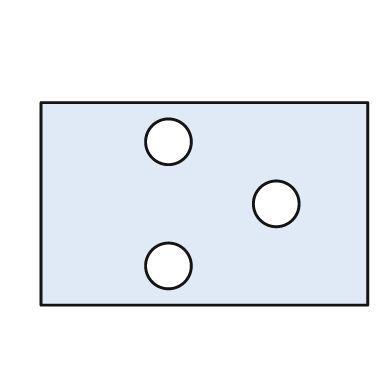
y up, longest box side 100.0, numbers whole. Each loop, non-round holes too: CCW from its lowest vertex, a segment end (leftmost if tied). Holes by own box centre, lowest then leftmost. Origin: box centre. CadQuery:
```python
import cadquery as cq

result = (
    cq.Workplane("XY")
    .moveTo(-50.0, -31.0)
    .lineTo(50.0, -31.0)
    .lineTo(50.0, 31.0)
    .lineTo(-50.0, 31.0)
    .close()
    .moveTo(-11.0, -19.0)
    .circle(7.0)
    .moveTo(22.0, 0.0)
    .circle(7.0)
    .moveTo(-11.0, 19.0)
    .circle(7.0)
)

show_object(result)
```